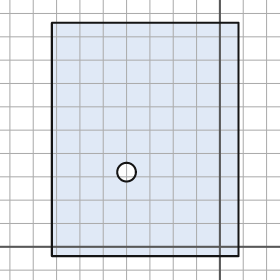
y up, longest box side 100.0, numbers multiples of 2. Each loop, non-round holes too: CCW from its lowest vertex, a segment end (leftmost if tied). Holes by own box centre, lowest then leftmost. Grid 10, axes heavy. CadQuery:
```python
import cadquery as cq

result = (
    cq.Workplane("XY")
    .moveTo(-72.0, -4.0)
    .lineTo(8.0, -4.0)
    .lineTo(8.0, 96.0)
    .lineTo(-72.0, 96.0)
    .close()
    .moveTo(-40.0, 32.0)
    .circle(4.0)
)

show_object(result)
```